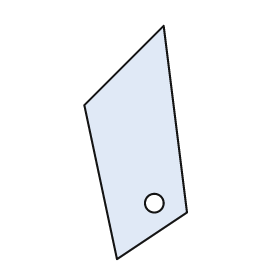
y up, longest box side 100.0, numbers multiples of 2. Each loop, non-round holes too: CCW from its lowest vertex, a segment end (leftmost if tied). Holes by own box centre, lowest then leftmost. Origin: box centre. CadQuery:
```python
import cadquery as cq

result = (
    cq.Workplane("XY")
    .moveTo(-8.0, -50.0)
    .lineTo(22.0, -30.0)
    .lineTo(12.0, 50.0)
    .lineTo(-22.0, 16.0)
    .close()
    .moveTo(8.0, -26.0)
    .circle(4.0)
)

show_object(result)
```